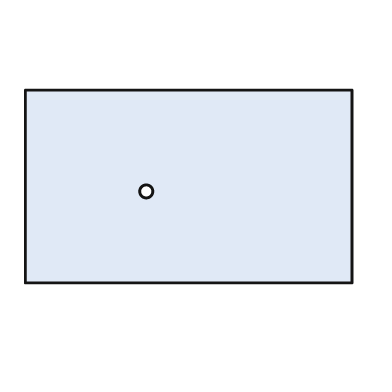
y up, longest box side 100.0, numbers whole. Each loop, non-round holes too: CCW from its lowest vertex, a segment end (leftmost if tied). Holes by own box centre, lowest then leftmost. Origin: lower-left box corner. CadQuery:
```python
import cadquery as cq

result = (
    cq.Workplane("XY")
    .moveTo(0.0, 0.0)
    .lineTo(100.0, 0.0)
    .lineTo(100.0, 59.0)
    .lineTo(0.0, 59.0)
    .close()
    .moveTo(37.0, 28.0)
    .circle(2.0)
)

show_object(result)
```